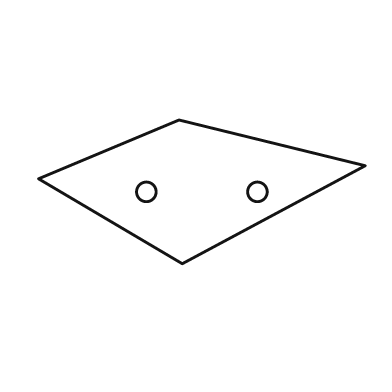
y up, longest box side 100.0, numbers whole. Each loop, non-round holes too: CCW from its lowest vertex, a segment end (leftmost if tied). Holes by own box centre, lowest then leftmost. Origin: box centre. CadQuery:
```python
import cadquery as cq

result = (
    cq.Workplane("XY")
    .moveTo(-6.0, -22.0)
    .lineTo(50.0, 8.0)
    .lineTo(-7.0, 22.0)
    .lineTo(-50.0, 4.0)
    .close()
    .moveTo(-17.0, 0.0)
    .circle(3.0)
    .moveTo(17.0, 0.0)
    .circle(3.0)
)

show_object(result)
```